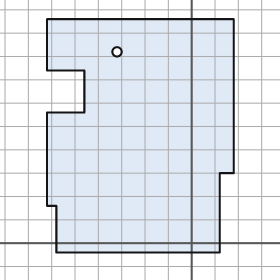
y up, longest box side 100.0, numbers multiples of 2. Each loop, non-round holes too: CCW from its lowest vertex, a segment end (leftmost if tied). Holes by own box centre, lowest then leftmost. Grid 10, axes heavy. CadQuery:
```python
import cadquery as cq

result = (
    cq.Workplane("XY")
    .moveTo(-58.0, -4.0)
    .lineTo(12.0, -4.0)
    .lineTo(12.0, 30.0)
    .lineTo(18.0, 30.0)
    .lineTo(18.0, 96.0)
    .lineTo(-62.0, 96.0)
    .lineTo(-62.0, 74.0)
    .lineTo(-46.0, 74.0)
    .lineTo(-46.0, 56.0)
    .lineTo(-62.0, 56.0)
    .lineTo(-62.0, 16.0)
    .lineTo(-58.0, 16.0)
    .close()
    .moveTo(-32.0, 82.0)
    .circle(2.0)
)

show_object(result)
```